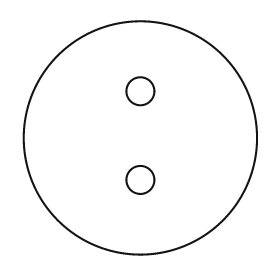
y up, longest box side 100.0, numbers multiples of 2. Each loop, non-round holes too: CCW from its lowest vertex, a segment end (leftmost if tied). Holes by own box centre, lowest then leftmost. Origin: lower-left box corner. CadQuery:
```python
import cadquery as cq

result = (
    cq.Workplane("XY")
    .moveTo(50.0, 50.0)
    .circle(50.0)
    .moveTo(50.0, 32.0)
    .circle(6.0)
    .moveTo(50.0, 70.0)
    .circle(6.0)
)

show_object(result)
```